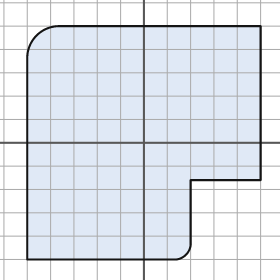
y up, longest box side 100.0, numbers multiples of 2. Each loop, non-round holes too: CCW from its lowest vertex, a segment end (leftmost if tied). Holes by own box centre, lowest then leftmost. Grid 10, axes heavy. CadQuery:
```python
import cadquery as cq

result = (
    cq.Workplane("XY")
    .moveTo(-50.0, -50.0)
    .lineTo(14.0, -50.0)
    .threePointArc((18.0, -48.0), (20.0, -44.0))
    .lineTo(20.0, -16.0)
    .lineTo(50.0, -16.0)
    .lineTo(50.0, 50.0)
    .lineTo(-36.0, 50.0)
    .threePointArc((-46.0, 46.0), (-50.0, 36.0))
    .close()
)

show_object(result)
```